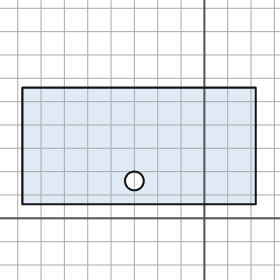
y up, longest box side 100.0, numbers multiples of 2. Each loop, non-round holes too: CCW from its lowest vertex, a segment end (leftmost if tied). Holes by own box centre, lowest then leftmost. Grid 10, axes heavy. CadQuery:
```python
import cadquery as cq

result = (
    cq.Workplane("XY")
    .moveTo(-78.0, 6.0)
    .lineTo(22.0, 6.0)
    .lineTo(22.0, 56.0)
    .lineTo(-78.0, 56.0)
    .close()
    .moveTo(-30.0, 16.0)
    .circle(4.0)
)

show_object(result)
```